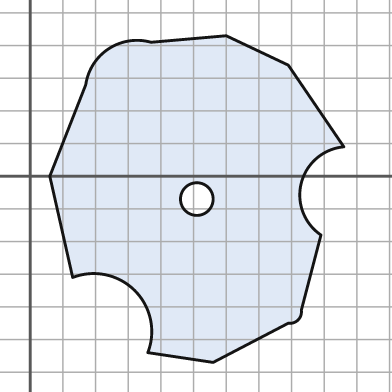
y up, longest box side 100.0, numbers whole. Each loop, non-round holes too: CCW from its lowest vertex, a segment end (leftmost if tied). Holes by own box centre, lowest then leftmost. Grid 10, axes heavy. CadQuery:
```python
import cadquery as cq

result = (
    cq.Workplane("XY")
    .moveTo(56.0, -57.0)
    .lineTo(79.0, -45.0)
    .threePointArc((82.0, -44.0), (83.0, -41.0))
    .lineTo(89.0, -18.0)
    .threePointArc((83.0, -2.0), (96.0, 9.0))
    .lineTo(79.0, 34.0)
    .lineTo(60.0, 43.0)
    .lineTo(37.0, 41.0)
    .threePointArc((24.0, 39.0), (17.0, 28.0))
    .lineTo(6.0, 0.0)
    .lineTo(13.0, -31.0)
    .threePointArc((32.0, -35.0), (36.0, -54.0))
    .close()
    .moveTo(51.0, -7.0)
    .circle(5.0)
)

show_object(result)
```